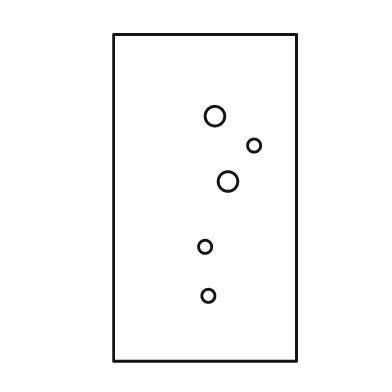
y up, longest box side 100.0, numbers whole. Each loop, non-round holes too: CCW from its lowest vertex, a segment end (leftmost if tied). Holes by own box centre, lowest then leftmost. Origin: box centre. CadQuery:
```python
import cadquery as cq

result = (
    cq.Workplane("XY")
    .moveTo(-28.0, -50.0)
    .lineTo(28.0, -50.0)
    .lineTo(28.0, 50.0)
    .lineTo(-28.0, 50.0)
    .close()
    .moveTo(1.0, -30.0)
    .circle(2.0)
    .moveTo(0.0, -15.0)
    .circle(2.0)
    .moveTo(7.0, 5.0)
    .circle(3.0)
    .moveTo(15.0, 16.0)
    .circle(2.0)
    .moveTo(3.0, 25.0)
    .circle(3.0)
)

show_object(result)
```